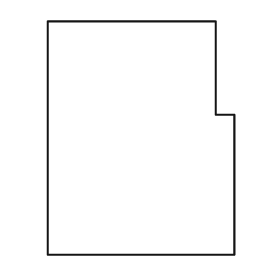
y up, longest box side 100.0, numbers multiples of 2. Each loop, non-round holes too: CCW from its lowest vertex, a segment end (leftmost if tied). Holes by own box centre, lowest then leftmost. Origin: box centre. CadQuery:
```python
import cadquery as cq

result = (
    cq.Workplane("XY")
    .moveTo(-40.0, -50.0)
    .lineTo(40.0, -50.0)
    .lineTo(40.0, 10.0)
    .lineTo(32.0, 10.0)
    .lineTo(32.0, 50.0)
    .lineTo(-40.0, 50.0)
    .close()
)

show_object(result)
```